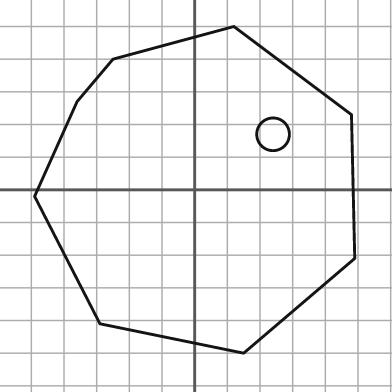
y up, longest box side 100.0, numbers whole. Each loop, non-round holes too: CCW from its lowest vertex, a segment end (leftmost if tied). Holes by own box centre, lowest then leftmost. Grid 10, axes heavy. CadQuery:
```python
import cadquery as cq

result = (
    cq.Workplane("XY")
    .moveTo(15.0, -50.0)
    .lineTo(49.0, -21.0)
    .lineTo(48.0, 23.0)
    .lineTo(12.0, 50.0)
    .lineTo(-25.0, 40.0)
    .lineTo(-36.0, 27.0)
    .lineTo(-49.0, -2.0)
    .lineTo(-29.0, -41.0)
    .close()
    .moveTo(24.0, 17.0)
    .circle(5.0)
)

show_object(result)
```